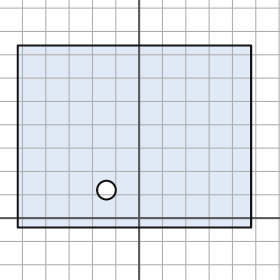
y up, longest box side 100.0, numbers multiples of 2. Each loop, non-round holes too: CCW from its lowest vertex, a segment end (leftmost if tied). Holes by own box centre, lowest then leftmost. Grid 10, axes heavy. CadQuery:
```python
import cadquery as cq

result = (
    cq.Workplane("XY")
    .moveTo(-52.0, -4.0)
    .lineTo(48.0, -4.0)
    .lineTo(48.0, 74.0)
    .lineTo(-52.0, 74.0)
    .close()
    .moveTo(-14.0, 12.0)
    .circle(4.0)
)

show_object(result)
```